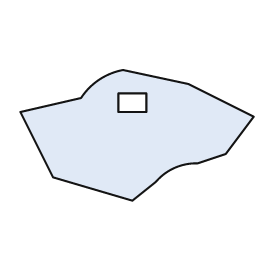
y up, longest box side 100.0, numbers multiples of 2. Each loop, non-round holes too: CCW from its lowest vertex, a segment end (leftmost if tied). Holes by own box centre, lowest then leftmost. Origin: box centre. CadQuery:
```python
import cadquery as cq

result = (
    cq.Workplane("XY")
    .moveTo(-2.0, -28.0)
    .lineTo(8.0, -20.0)
    .threePointArc((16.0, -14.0), (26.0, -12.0))
    .lineTo(38.0, -8.0)
    .lineTo(50.0, 8.0)
    .lineTo(22.0, 22.0)
    .lineTo(-6.0, 28.0)
    .threePointArc((-16.0, 24.0), (-24.0, 16.0))
    .lineTo(-50.0, 10.0)
    .lineTo(-36.0, -18.0)
    .close()
    .moveTo(-8.0, 10.0)
    .lineTo(4.0, 10.0)
    .lineTo(4.0, 18.0)
    .lineTo(-8.0, 18.0)
    .close()
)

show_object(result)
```